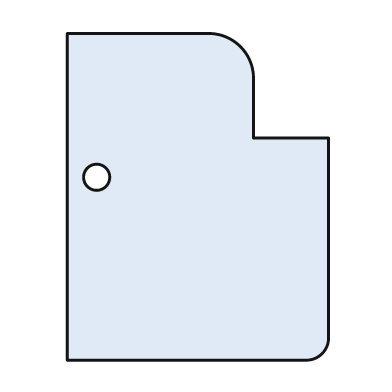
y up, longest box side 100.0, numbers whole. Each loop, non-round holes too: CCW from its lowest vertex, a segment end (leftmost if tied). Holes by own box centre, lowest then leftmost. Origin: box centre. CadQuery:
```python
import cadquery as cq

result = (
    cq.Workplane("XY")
    .moveTo(-40.0, -50.0)
    .lineTo(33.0, -50.0)
    .threePointArc((38.0, -48.0), (40.0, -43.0))
    .lineTo(40.0, 18.0)
    .lineTo(17.0, 18.0)
    .lineTo(17.0, 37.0)
    .threePointArc((13.0, 46.0), (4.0, 50.0))
    .lineTo(-40.0, 50.0)
    .close()
    .moveTo(-31.0, 6.0)
    .circle(4.0)
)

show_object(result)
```